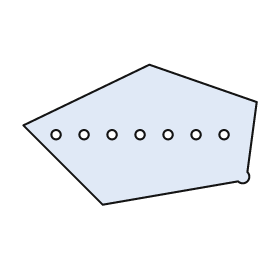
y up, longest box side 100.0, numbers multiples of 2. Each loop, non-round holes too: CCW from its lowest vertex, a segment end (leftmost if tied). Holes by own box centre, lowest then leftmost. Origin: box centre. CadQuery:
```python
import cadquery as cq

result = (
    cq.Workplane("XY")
    .moveTo(-16.0, -30.0)
    .lineTo(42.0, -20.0)
    .threePointArc((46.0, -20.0), (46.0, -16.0))
    .lineTo(50.0, 14.0)
    .lineTo(4.0, 30.0)
    .lineTo(-50.0, 4.0)
    .close()
    .moveTo(-36.0, 0.0)
    .circle(2.0)
    .moveTo(-24.0, 0.0)
    .circle(2.0)
    .moveTo(-12.0, 0.0)
    .circle(2.0)
    .moveTo(0.0, 0.0)
    .circle(2.0)
    .moveTo(12.0, 0.0)
    .circle(2.0)
    .moveTo(24.0, 0.0)
    .circle(2.0)
    .moveTo(36.0, 0.0)
    .circle(2.0)
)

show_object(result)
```